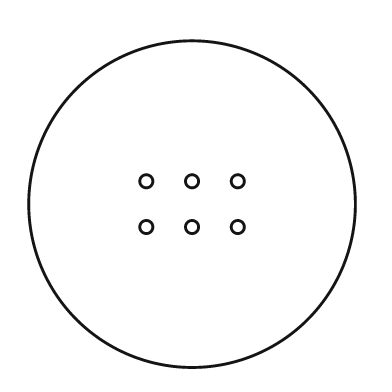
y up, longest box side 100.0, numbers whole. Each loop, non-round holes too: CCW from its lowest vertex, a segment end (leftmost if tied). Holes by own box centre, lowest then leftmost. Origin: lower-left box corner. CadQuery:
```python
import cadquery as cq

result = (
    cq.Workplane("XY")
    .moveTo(50.0, 50.0)
    .circle(50.0)
    .moveTo(36.0, 43.0)
    .circle(2.0)
    .moveTo(50.0, 43.0)
    .circle(2.0)
    .moveTo(64.0, 43.0)
    .circle(2.0)
    .moveTo(36.0, 57.0)
    .circle(2.0)
    .moveTo(50.0, 57.0)
    .circle(2.0)
    .moveTo(64.0, 57.0)
    .circle(2.0)
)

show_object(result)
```